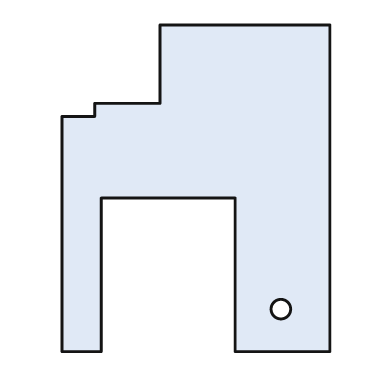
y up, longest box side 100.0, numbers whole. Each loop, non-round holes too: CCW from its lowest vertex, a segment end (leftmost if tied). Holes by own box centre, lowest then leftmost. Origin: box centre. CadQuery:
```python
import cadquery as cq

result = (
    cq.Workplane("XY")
    .moveTo(-41.0, -50.0)
    .lineTo(-29.0, -50.0)
    .lineTo(-29.0, -3.0)
    .lineTo(12.0, -3.0)
    .lineTo(12.0, -50.0)
    .lineTo(41.0, -50.0)
    .lineTo(41.0, 50.0)
    .lineTo(-11.0, 50.0)
    .lineTo(-11.0, 26.0)
    .lineTo(-31.0, 26.0)
    .lineTo(-31.0, 22.0)
    .lineTo(-41.0, 22.0)
    .close()
    .moveTo(26.0, -37.0)
    .circle(3.0)
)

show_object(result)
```